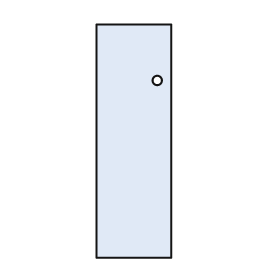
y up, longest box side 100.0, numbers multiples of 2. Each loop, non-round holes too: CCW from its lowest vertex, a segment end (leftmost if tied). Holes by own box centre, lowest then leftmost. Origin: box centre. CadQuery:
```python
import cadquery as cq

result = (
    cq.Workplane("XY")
    .moveTo(-16.0, -50.0)
    .lineTo(16.0, -50.0)
    .lineTo(16.0, 50.0)
    .lineTo(-16.0, 50.0)
    .close()
    .moveTo(10.0, 26.0)
    .circle(2.0)
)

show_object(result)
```